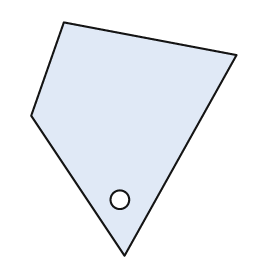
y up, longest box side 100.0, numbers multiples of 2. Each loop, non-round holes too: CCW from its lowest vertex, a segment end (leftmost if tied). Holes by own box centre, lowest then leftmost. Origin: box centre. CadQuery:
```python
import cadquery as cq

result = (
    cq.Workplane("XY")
    .moveTo(-4.0, -50.0)
    .lineTo(44.0, 36.0)
    .lineTo(-30.0, 50.0)
    .lineTo(-44.0, 10.0)
    .close()
    .moveTo(-6.0, -26.0)
    .circle(4.0)
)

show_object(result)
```